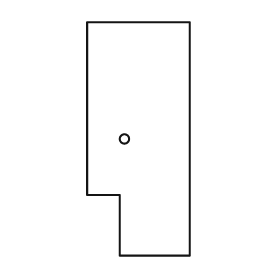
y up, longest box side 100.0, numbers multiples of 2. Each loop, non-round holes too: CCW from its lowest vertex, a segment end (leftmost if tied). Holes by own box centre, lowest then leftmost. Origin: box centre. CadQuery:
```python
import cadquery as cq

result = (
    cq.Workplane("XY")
    .moveTo(-8.0, -50.0)
    .lineTo(22.0, -50.0)
    .lineTo(22.0, 50.0)
    .lineTo(-22.0, 50.0)
    .lineTo(-22.0, -24.0)
    .lineTo(-8.0, -24.0)
    .close()
    .moveTo(-6.0, 0.0)
    .circle(2.0)
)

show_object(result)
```